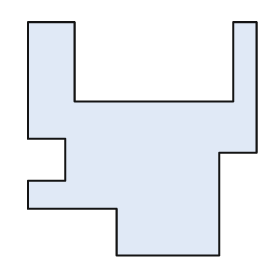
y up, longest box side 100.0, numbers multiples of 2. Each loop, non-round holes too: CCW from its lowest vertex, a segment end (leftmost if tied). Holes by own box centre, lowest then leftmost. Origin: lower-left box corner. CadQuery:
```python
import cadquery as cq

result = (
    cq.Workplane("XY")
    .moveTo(38.0, 0.0)
    .lineTo(82.0, 0.0)
    .lineTo(82.0, 44.0)
    .lineTo(98.0, 44.0)
    .lineTo(98.0, 100.0)
    .lineTo(88.0, 100.0)
    .lineTo(88.0, 66.0)
    .lineTo(20.0, 66.0)
    .lineTo(20.0, 100.0)
    .lineTo(0.0, 100.0)
    .lineTo(0.0, 50.0)
    .lineTo(16.0, 50.0)
    .lineTo(16.0, 32.0)
    .lineTo(0.0, 32.0)
    .lineTo(0.0, 20.0)
    .lineTo(38.0, 20.0)
    .close()
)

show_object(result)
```